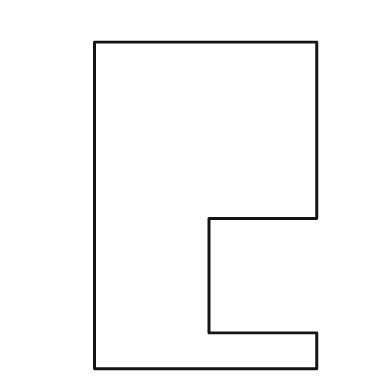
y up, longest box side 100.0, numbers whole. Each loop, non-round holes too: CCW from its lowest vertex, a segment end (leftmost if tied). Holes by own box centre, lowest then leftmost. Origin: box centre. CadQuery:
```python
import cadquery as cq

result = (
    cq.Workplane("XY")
    .moveTo(-34.0, -50.0)
    .lineTo(34.0, -50.0)
    .lineTo(34.0, -39.0)
    .lineTo(1.0, -39.0)
    .lineTo(1.0, -4.0)
    .lineTo(34.0, -4.0)
    .lineTo(34.0, 50.0)
    .lineTo(-34.0, 50.0)
    .close()
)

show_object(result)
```